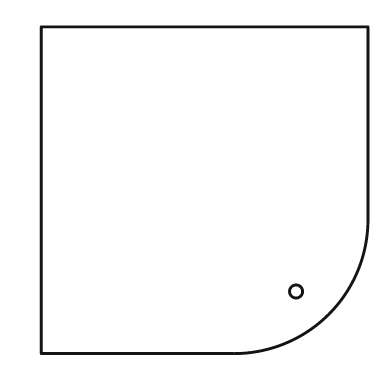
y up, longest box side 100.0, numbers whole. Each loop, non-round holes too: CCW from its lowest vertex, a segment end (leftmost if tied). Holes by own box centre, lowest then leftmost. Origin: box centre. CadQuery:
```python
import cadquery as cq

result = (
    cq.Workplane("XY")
    .moveTo(-50.0, -50.0)
    .lineTo(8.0, -50.0)
    .threePointArc((38.0, -38.0), (50.0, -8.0))
    .lineTo(50.0, 50.0)
    .lineTo(-50.0, 50.0)
    .close()
    .moveTo(28.0, -31.0)
    .circle(2.0)
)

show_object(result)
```